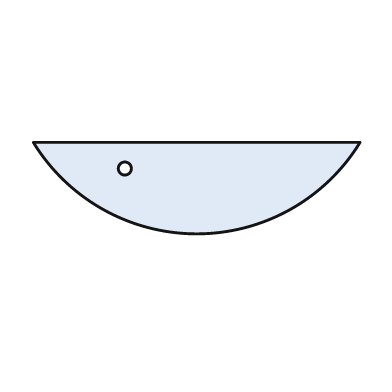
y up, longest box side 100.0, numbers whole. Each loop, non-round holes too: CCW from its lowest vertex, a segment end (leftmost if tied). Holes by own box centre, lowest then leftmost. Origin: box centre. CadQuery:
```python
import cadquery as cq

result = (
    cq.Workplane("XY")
    .moveTo(-50.0, 14.0)
    .threePointArc((0.0, -14.0), (50.0, 14.0))
    .close()
    .moveTo(-22.0, 6.0)
    .circle(2.0)
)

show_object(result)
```